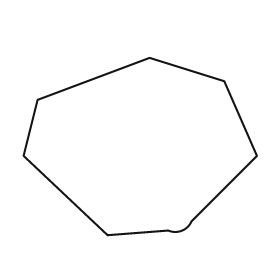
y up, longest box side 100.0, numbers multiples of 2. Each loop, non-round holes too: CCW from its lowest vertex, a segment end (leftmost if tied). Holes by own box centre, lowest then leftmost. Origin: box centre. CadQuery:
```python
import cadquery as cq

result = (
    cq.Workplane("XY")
    .moveTo(-14.0, -38.0)
    .lineTo(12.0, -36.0)
    .threePointArc((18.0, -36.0), (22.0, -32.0))
    .lineTo(50.0, -4.0)
    .lineTo(36.0, 28.0)
    .lineTo(4.0, 38.0)
    .lineTo(-44.0, 20.0)
    .lineTo(-50.0, -4.0)
    .close()
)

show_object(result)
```